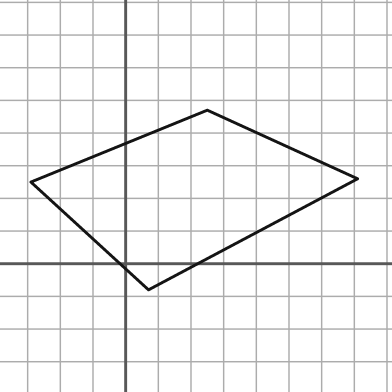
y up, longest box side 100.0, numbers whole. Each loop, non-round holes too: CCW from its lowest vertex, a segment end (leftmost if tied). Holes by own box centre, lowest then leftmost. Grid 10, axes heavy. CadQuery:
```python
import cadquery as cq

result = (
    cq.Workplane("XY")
    .moveTo(7.0, -8.0)
    .lineTo(71.0, 26.0)
    .lineTo(25.0, 47.0)
    .lineTo(-29.0, 25.0)
    .close()
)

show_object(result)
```